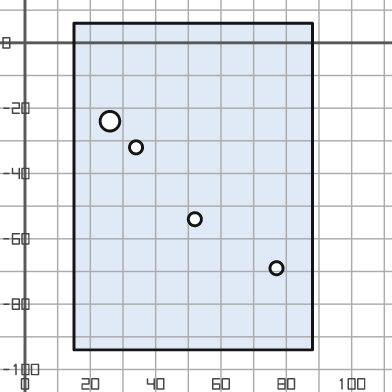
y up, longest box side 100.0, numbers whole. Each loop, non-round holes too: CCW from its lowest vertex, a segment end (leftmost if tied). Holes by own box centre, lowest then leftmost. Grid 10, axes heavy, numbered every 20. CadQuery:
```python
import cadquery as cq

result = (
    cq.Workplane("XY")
    .moveTo(15.0, -94.0)
    .lineTo(88.0, -94.0)
    .lineTo(88.0, 6.0)
    .lineTo(15.0, 6.0)
    .close()
    .moveTo(77.0, -69.0)
    .circle(2.0)
    .moveTo(52.0, -54.0)
    .circle(2.0)
    .moveTo(34.0, -32.0)
    .circle(2.0)
    .moveTo(26.0, -24.0)
    .circle(3.0)
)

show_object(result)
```